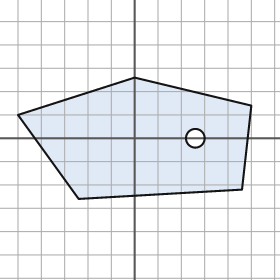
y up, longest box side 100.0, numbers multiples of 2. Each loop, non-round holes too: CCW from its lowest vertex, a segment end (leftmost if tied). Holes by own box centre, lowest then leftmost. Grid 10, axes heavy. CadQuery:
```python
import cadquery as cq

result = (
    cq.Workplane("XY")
    .moveTo(-24.0, -26.0)
    .lineTo(46.0, -22.0)
    .lineTo(50.0, 14.0)
    .lineTo(0.0, 26.0)
    .lineTo(-50.0, 10.0)
    .close()
    .moveTo(26.0, 0.0)
    .circle(4.0)
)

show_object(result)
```